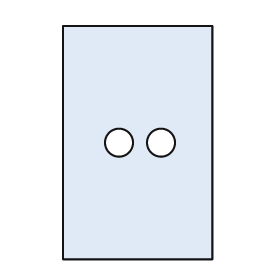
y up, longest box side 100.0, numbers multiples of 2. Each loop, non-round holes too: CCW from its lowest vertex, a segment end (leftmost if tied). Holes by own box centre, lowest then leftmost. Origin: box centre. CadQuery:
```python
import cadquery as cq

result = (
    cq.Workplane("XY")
    .moveTo(-32.0, -50.0)
    .lineTo(32.0, -50.0)
    .lineTo(32.0, 50.0)
    .lineTo(-32.0, 50.0)
    .close()
    .moveTo(-8.0, 0.0)
    .circle(6.0)
    .moveTo(10.0, 0.0)
    .circle(6.0)
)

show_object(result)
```